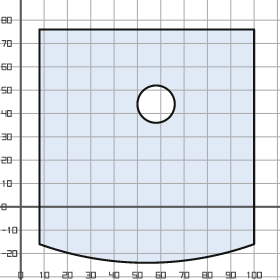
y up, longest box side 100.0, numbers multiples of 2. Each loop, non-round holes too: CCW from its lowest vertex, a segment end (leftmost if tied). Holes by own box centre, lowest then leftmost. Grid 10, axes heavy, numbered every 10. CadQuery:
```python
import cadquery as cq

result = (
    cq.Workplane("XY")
    .moveTo(8.0, -16.0)
    .threePointArc((54.0, -24.0), (100.0, -16.0))
    .lineTo(100.0, 76.0)
    .lineTo(8.0, 76.0)
    .close()
    .moveTo(58.0, 44.0)
    .circle(8.0)
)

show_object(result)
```